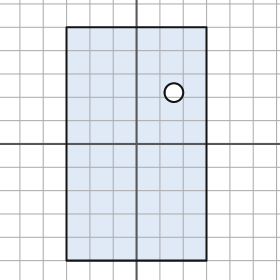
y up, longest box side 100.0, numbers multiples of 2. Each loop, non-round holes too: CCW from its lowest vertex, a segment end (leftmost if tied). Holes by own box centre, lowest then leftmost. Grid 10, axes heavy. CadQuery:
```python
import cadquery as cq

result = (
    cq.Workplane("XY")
    .moveTo(-30.0, -50.0)
    .lineTo(30.0, -50.0)
    .lineTo(30.0, 50.0)
    .lineTo(-30.0, 50.0)
    .close()
    .moveTo(16.0, 22.0)
    .circle(4.0)
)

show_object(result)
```